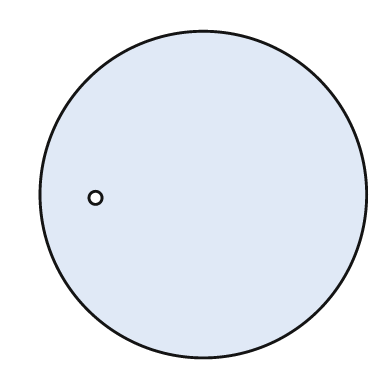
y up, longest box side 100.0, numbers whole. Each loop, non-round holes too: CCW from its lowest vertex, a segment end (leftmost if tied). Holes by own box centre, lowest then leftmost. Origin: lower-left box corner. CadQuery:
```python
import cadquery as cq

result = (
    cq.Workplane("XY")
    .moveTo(50.0, 50.0)
    .circle(50.0)
    .moveTo(17.0, 49.0)
    .circle(2.0)
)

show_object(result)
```